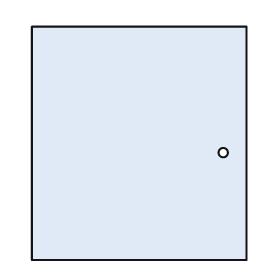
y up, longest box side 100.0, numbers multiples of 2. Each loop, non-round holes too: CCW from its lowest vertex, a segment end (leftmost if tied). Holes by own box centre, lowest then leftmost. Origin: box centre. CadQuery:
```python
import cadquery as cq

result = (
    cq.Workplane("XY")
    .moveTo(-46.0, -50.0)
    .lineTo(46.0, -50.0)
    .lineTo(46.0, 50.0)
    .lineTo(-46.0, 50.0)
    .close()
    .moveTo(36.0, -4.0)
    .circle(2.0)
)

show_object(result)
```